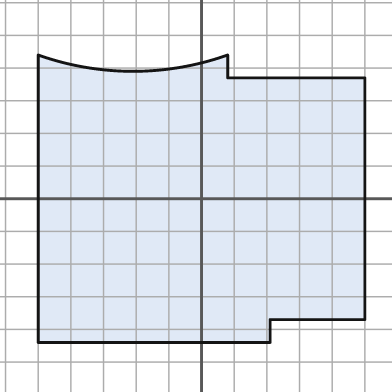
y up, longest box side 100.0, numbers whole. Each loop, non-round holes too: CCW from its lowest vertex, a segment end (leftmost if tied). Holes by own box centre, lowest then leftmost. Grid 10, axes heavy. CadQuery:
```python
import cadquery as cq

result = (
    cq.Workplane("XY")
    .moveTo(-50.0, -44.0)
    .lineTo(21.0, -44.0)
    .lineTo(21.0, -37.0)
    .lineTo(50.0, -37.0)
    .lineTo(50.0, 37.0)
    .lineTo(8.0, 37.0)
    .lineTo(8.0, 44.0)
    .threePointArc((-21.0, 39.0), (-50.0, 44.0))
    .close()
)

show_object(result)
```